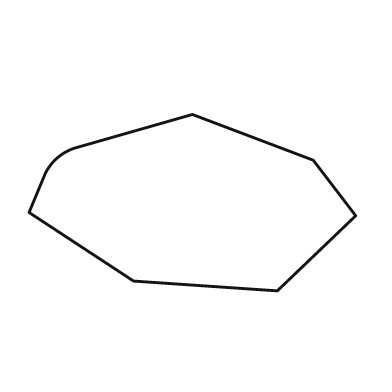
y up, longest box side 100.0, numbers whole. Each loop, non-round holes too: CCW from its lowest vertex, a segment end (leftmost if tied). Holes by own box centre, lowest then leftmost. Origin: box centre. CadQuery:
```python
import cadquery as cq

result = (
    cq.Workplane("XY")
    .moveTo(26.0, -27.0)
    .lineTo(50.0, -4.0)
    .lineTo(37.0, 13.0)
    .lineTo(0.0, 27.0)
    .lineTo(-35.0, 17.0)
    .threePointArc((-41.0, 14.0), (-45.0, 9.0))
    .lineTo(-50.0, -3.0)
    .lineTo(-18.0, -24.0)
    .close()
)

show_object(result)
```